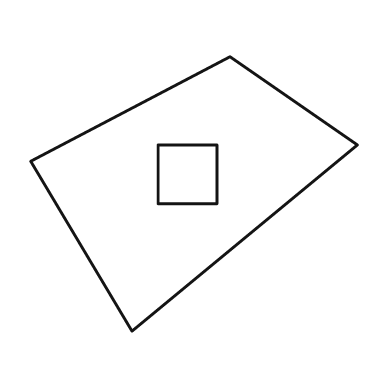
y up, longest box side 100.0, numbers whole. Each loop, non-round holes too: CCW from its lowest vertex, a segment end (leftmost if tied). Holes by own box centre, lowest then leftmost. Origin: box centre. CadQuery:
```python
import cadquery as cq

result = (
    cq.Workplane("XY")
    .moveTo(-19.0, -42.0)
    .lineTo(50.0, 15.0)
    .lineTo(11.0, 42.0)
    .lineTo(-50.0, 10.0)
    .close()
    .moveTo(-11.0, -3.0)
    .lineTo(7.0, -3.0)
    .lineTo(7.0, 15.0)
    .lineTo(-11.0, 15.0)
    .close()
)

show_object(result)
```